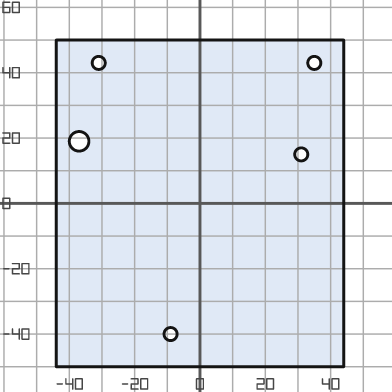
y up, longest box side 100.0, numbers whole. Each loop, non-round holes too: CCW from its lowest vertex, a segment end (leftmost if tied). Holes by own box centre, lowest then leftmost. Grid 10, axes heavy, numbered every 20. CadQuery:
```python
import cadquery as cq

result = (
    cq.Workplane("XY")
    .moveTo(-44.0, -50.0)
    .lineTo(44.0, -50.0)
    .lineTo(44.0, 50.0)
    .lineTo(-44.0, 50.0)
    .close()
    .moveTo(-9.0, -40.0)
    .circle(2.0)
    .moveTo(31.0, 15.0)
    .circle(2.0)
    .moveTo(-37.0, 19.0)
    .circle(3.0)
    .moveTo(-31.0, 43.0)
    .circle(2.0)
    .moveTo(35.0, 43.0)
    .circle(2.0)
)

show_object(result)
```